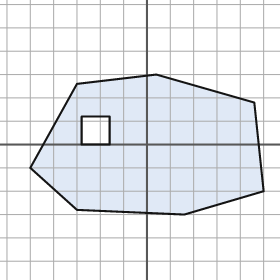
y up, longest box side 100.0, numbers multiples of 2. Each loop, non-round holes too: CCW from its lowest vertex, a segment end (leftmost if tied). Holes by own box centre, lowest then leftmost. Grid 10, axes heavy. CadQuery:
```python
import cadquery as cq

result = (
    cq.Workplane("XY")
    .moveTo(16.0, -30.0)
    .lineTo(50.0, -20.0)
    .lineTo(46.0, 18.0)
    .lineTo(4.0, 30.0)
    .lineTo(-30.0, 26.0)
    .lineTo(-50.0, -10.0)
    .lineTo(-30.0, -28.0)
    .close()
    .moveTo(-28.0, 0.0)
    .lineTo(-16.0, 0.0)
    .lineTo(-16.0, 12.0)
    .lineTo(-28.0, 12.0)
    .close()
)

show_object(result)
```